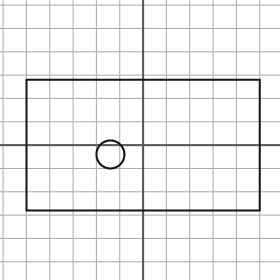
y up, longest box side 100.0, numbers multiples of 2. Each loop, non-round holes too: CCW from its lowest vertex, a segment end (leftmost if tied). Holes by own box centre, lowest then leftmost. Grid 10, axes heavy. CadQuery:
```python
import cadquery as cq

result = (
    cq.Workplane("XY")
    .moveTo(-50.0, -28.0)
    .lineTo(50.0, -28.0)
    .lineTo(50.0, 28.0)
    .lineTo(-50.0, 28.0)
    .close()
    .moveTo(-14.0, -4.0)
    .circle(6.0)
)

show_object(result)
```